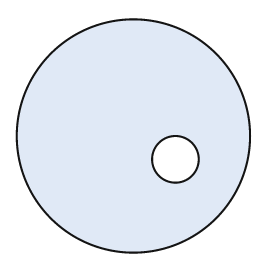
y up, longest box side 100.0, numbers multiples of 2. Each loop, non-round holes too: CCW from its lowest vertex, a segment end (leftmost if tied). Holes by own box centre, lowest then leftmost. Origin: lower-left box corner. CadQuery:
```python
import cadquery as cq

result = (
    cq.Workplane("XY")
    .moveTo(50.0, 50.0)
    .circle(50.0)
    .moveTo(68.0, 40.0)
    .circle(10.0)
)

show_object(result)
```